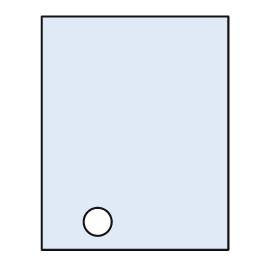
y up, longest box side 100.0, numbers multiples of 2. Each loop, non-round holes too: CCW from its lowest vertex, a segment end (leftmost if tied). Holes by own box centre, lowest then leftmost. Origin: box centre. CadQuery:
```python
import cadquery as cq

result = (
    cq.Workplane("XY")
    .moveTo(-40.0, -50.0)
    .lineTo(40.0, -50.0)
    .lineTo(40.0, 50.0)
    .lineTo(-40.0, 50.0)
    .close()
    .moveTo(-16.0, -38.0)
    .circle(6.0)
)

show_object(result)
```